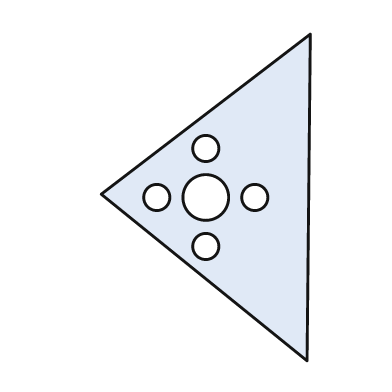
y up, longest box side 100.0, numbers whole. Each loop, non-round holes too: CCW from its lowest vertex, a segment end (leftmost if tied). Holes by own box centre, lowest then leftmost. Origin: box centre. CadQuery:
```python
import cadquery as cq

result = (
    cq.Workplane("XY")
    .moveTo(31.0, -50.0)
    .lineTo(32.0, 50.0)
    .lineTo(-32.0, 1.0)
    .close()
    .moveTo(0.0, -15.0)
    .circle(4.0)
    .moveTo(-15.0, 0.0)
    .circle(4.0)
    .moveTo(0.0, 0.0)
    .circle(7.0)
    .moveTo(15.0, 0.0)
    .circle(4.0)
    .moveTo(0.0, 15.0)
    .circle(4.0)
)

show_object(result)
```